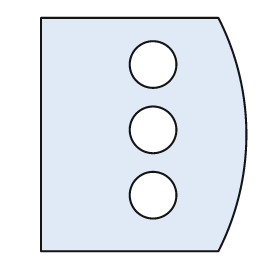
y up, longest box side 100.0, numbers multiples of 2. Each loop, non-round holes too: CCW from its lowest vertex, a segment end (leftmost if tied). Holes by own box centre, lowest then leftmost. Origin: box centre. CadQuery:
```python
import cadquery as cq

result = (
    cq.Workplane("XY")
    .moveTo(-44.0, -50.0)
    .lineTo(32.0, -50.0)
    .threePointArc((44.0, 0.0), (32.0, 50.0))
    .lineTo(-44.0, 50.0)
    .close()
    .moveTo(4.0, -26.0)
    .circle(10.0)
    .moveTo(4.0, 2.0)
    .circle(10.0)
    .moveTo(4.0, 30.0)
    .circle(10.0)
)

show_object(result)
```